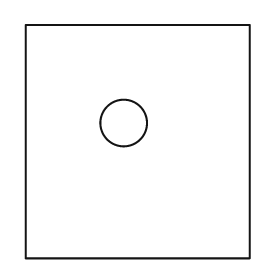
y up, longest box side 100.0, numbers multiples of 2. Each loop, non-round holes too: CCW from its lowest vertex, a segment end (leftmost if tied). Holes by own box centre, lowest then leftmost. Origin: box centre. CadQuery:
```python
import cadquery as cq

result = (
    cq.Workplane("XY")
    .moveTo(-48.0, -50.0)
    .lineTo(48.0, -50.0)
    .lineTo(48.0, 50.0)
    .lineTo(-48.0, 50.0)
    .close()
    .moveTo(-6.0, 8.0)
    .circle(10.0)
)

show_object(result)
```